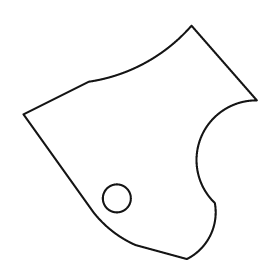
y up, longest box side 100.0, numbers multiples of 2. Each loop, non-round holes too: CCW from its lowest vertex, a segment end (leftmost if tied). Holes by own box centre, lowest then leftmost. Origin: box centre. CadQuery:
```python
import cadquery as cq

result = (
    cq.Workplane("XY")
    .moveTo(20.0, -50.0)
    .threePointArc((30.0, -40.0), (32.0, -26.0))
    .threePointArc((26.0, 2.0), (50.0, 18.0))
    .lineTo(22.0, 50.0)
    .threePointArc((2.0, 34.0), (-22.0, 26.0))
    .lineTo(-50.0, 12.0)
    .lineTo(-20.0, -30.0)
    .threePointArc((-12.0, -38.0), (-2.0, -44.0))
    .close()
    .moveTo(-10.0, -24.0)
    .circle(6.0)
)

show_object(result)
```